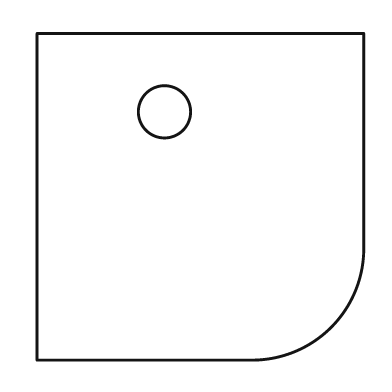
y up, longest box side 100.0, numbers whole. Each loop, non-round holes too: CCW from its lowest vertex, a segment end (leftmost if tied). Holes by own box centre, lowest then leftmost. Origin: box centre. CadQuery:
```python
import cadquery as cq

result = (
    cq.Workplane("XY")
    .moveTo(-50.0, -50.0)
    .lineTo(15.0, -50.0)
    .threePointArc((40.0, -40.0), (50.0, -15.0))
    .lineTo(50.0, 50.0)
    .lineTo(-50.0, 50.0)
    .close()
    .moveTo(-11.0, 26.0)
    .circle(8.0)
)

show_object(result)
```